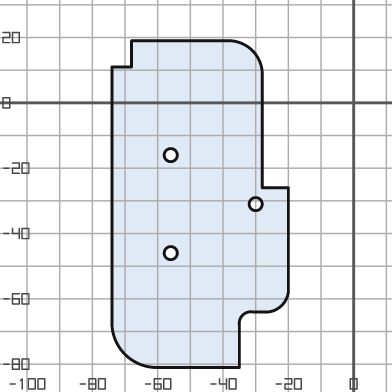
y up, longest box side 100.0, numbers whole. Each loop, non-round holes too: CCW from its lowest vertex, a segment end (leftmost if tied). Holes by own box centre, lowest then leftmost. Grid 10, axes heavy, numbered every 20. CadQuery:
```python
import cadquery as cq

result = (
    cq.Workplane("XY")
    .moveTo(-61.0, -81.0)
    .lineTo(-35.0, -81.0)
    .lineTo(-35.0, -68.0)
    .threePointArc((-34.0, -65.0), (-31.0, -64.0))
    .lineTo(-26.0, -64.0)
    .threePointArc((-22.0, -62.0), (-20.0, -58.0))
    .lineTo(-20.0, -26.0)
    .lineTo(-28.0, -26.0)
    .lineTo(-28.0, 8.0)
    .threePointArc((-31.0, 16.0), (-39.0, 19.0))
    .lineTo(-68.0, 19.0)
    .lineTo(-68.0, 11.0)
    .lineTo(-74.0, 11.0)
    .lineTo(-74.0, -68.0)
    .threePointArc((-70.0, -77.0), (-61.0, -81.0))
    .close()
    .moveTo(-56.0, -46.0)
    .circle(2.0)
    .moveTo(-30.0, -31.0)
    .circle(2.0)
    .moveTo(-56.0, -16.0)
    .circle(2.0)
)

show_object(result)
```